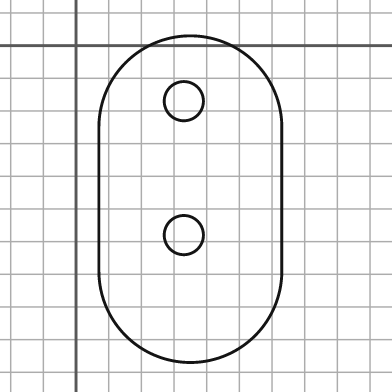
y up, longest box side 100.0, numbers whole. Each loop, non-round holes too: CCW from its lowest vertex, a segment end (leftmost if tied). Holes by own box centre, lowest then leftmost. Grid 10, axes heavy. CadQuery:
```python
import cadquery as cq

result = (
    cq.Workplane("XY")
    .moveTo(7.0, -69.0)
    .threePointArc((35.0, -97.0), (63.0, -69.0))
    .lineTo(63.0, -25.0)
    .threePointArc((35.0, 3.0), (7.0, -25.0))
    .close()
    .moveTo(33.0, -58.0)
    .circle(6.0)
    .moveTo(33.0, -17.0)
    .circle(6.0)
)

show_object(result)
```